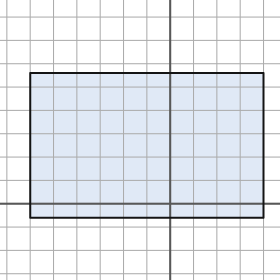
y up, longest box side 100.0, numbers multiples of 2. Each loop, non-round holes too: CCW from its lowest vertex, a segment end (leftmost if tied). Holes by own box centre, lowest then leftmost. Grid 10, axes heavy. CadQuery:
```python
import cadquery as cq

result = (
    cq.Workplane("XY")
    .moveTo(-60.0, -6.0)
    .lineTo(40.0, -6.0)
    .lineTo(40.0, 56.0)
    .lineTo(-60.0, 56.0)
    .close()
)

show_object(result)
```